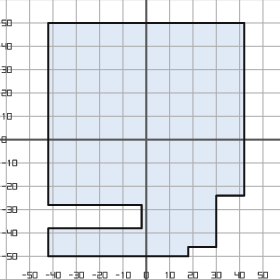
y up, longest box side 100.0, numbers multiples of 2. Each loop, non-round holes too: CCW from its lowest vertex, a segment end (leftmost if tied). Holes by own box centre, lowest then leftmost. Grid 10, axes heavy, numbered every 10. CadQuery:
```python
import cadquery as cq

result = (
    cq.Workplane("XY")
    .moveTo(-42.0, -50.0)
    .lineTo(18.0, -50.0)
    .lineTo(18.0, -46.0)
    .lineTo(30.0, -46.0)
    .lineTo(30.0, -24.0)
    .lineTo(42.0, -24.0)
    .lineTo(42.0, 50.0)
    .lineTo(-42.0, 50.0)
    .lineTo(-42.0, -28.0)
    .lineTo(-2.0, -28.0)
    .lineTo(-2.0, -38.0)
    .lineTo(-42.0, -38.0)
    .close()
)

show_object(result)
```